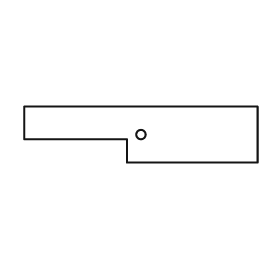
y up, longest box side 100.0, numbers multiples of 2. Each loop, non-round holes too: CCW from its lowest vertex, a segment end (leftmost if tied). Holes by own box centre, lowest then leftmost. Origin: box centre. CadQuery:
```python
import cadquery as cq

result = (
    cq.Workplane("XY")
    .moveTo(-6.0, -12.0)
    .lineTo(50.0, -12.0)
    .lineTo(50.0, 12.0)
    .lineTo(-50.0, 12.0)
    .lineTo(-50.0, -2.0)
    .lineTo(-6.0, -2.0)
    .close()
    .moveTo(0.0, 0.0)
    .circle(2.0)
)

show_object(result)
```